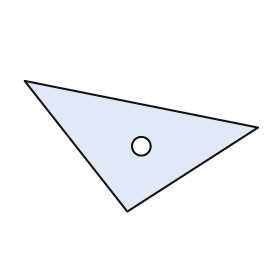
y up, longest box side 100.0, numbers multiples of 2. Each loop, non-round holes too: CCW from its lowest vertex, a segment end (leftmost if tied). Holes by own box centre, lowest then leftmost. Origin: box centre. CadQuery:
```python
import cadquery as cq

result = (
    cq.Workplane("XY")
    .moveTo(-6.0, -28.0)
    .lineTo(50.0, 8.0)
    .lineTo(-50.0, 28.0)
    .close()
    .moveTo(0.0, 0.0)
    .circle(4.0)
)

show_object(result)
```